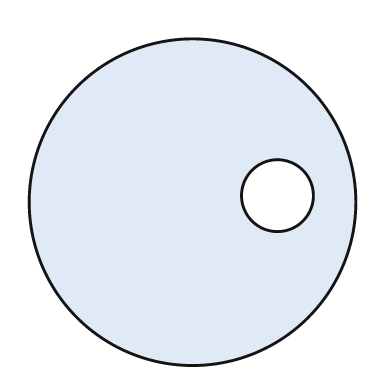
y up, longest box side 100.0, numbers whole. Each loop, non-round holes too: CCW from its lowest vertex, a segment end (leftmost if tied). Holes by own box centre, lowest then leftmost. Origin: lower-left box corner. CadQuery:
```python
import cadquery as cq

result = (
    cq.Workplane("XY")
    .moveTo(50.0, 50.0)
    .circle(50.0)
    .moveTo(76.0, 52.0)
    .circle(11.0)
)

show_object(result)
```